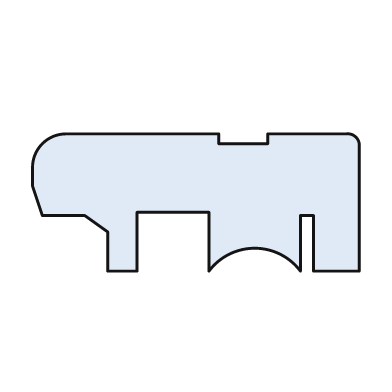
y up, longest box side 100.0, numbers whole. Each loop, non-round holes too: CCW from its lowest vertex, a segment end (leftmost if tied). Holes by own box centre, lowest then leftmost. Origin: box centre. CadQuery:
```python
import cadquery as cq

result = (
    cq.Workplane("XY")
    .moveTo(-27.0, -21.0)
    .lineTo(-18.0, -21.0)
    .lineTo(-18.0, -3.0)
    .lineTo(4.0, -3.0)
    .lineTo(4.0, -21.0)
    .threePointArc((18.0, -14.0), (32.0, -21.0))
    .lineTo(32.0, -4.0)
    .lineTo(36.0, -4.0)
    .lineTo(36.0, -21.0)
    .lineTo(50.0, -21.0)
    .lineTo(50.0, 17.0)
    .threePointArc((49.0, 20.0), (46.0, 21.0))
    .lineTo(22.0, 21.0)
    .lineTo(22.0, 18.0)
    .lineTo(7.0, 18.0)
    .lineTo(7.0, 21.0)
    .lineTo(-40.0, 21.0)
    .threePointArc((-47.0, 18.0), (-50.0, 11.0))
    .lineTo(-50.0, 5.0)
    .lineTo(-47.0, -4.0)
    .lineTo(-34.0, -4.0)
    .lineTo(-27.0, -9.0)
    .close()
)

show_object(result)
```